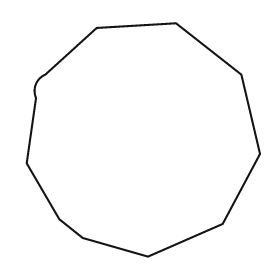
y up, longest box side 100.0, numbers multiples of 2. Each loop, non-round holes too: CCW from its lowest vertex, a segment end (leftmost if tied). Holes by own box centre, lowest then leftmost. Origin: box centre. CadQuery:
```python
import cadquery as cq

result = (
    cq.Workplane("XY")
    .moveTo(2.0, -50.0)
    .lineTo(34.0, -36.0)
    .lineTo(50.0, -6.0)
    .lineTo(42.0, 28.0)
    .lineTo(14.0, 50.0)
    .lineTo(-20.0, 48.0)
    .lineTo(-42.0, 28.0)
    .threePointArc((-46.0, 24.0), (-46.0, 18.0))
    .lineTo(-50.0, -10.0)
    .lineTo(-36.0, -34.0)
    .lineTo(-26.0, -42.0)
    .close()
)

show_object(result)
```